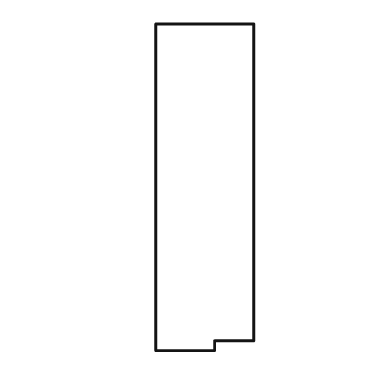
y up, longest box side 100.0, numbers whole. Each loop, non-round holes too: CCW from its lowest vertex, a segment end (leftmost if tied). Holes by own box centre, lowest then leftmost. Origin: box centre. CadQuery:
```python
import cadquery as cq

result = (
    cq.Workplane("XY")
    .moveTo(-15.0, -50.0)
    .lineTo(3.0, -50.0)
    .lineTo(3.0, -47.0)
    .lineTo(15.0, -47.0)
    .lineTo(15.0, 50.0)
    .lineTo(-15.0, 50.0)
    .close()
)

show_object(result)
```